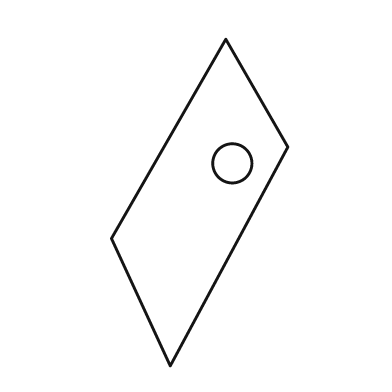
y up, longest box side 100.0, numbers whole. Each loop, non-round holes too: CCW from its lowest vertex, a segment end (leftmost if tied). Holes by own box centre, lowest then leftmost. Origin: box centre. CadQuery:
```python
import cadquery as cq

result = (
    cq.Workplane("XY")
    .moveTo(-9.0, -50.0)
    .lineTo(27.0, 17.0)
    .lineTo(8.0, 50.0)
    .lineTo(-27.0, -11.0)
    .close()
    .moveTo(10.0, 12.0)
    .circle(6.0)
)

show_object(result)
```